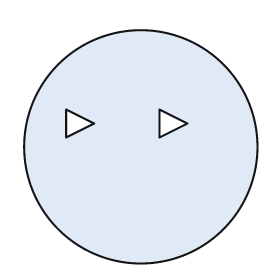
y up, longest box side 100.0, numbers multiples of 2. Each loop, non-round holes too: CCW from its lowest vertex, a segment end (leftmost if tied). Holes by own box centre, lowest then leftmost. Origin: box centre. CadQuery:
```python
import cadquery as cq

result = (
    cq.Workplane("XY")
    .moveTo(0.0, 0.0)
    .circle(50.0)
    .moveTo(-32.0, 4.0)
    .lineTo(-20.0, 10.0)
    .lineTo(-32.0, 16.0)
    .close()
    .moveTo(8.0, 4.0)
    .lineTo(20.0, 10.0)
    .lineTo(8.0, 16.0)
    .close()
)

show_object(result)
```